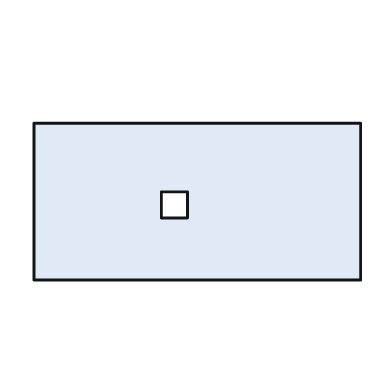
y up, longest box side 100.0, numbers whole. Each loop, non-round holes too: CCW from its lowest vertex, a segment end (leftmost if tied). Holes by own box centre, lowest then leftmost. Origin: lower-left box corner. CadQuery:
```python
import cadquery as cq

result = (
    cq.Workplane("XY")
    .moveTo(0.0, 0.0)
    .lineTo(100.0, 0.0)
    .lineTo(100.0, 48.0)
    .lineTo(0.0, 48.0)
    .close()
    .moveTo(39.0, 19.0)
    .lineTo(47.0, 19.0)
    .lineTo(47.0, 27.0)
    .lineTo(39.0, 27.0)
    .close()
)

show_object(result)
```